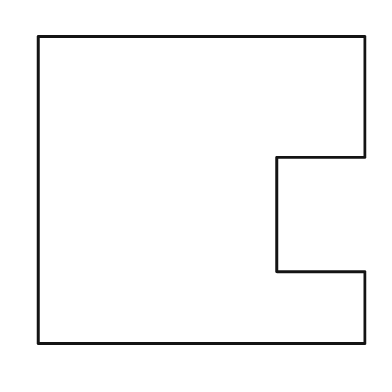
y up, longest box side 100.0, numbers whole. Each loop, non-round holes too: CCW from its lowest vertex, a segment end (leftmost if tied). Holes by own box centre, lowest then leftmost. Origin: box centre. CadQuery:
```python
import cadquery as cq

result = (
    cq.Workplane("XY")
    .moveTo(-50.0, -47.0)
    .lineTo(50.0, -47.0)
    .lineTo(50.0, -25.0)
    .lineTo(23.0, -25.0)
    .lineTo(23.0, 10.0)
    .lineTo(50.0, 10.0)
    .lineTo(50.0, 47.0)
    .lineTo(-50.0, 47.0)
    .close()
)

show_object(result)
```